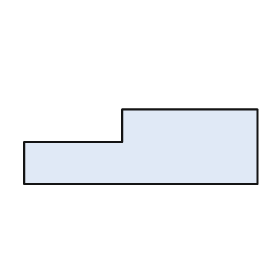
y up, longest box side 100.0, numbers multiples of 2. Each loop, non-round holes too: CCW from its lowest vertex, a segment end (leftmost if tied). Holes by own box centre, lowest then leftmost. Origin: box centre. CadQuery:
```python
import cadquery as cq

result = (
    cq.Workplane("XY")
    .moveTo(-50.0, -16.0)
    .lineTo(50.0, -16.0)
    .lineTo(50.0, 16.0)
    .lineTo(-8.0, 16.0)
    .lineTo(-8.0, 2.0)
    .lineTo(-50.0, 2.0)
    .close()
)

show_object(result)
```